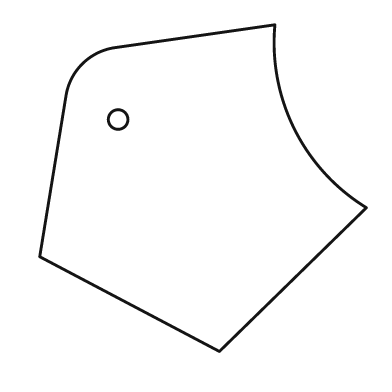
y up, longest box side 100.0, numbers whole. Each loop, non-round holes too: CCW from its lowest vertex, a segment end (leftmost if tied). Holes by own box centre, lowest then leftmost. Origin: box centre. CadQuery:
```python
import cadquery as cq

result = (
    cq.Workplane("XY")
    .moveTo(5.0, -50.0)
    .lineTo(50.0, -6.0)
    .threePointArc((28.0, 18.0), (22.0, 50.0))
    .lineTo(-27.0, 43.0)
    .threePointArc((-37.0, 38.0), (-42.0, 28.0))
    .lineTo(-50.0, -21.0)
    .close()
    .moveTo(-26.0, 21.0)
    .circle(3.0)
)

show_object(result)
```